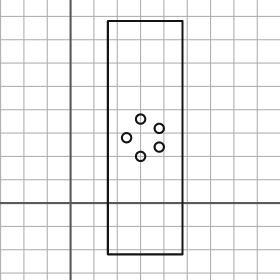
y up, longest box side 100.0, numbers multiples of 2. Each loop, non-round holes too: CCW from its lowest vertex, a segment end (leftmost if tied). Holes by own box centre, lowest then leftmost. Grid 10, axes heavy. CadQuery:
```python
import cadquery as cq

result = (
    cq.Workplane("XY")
    .moveTo(16.0, -22.0)
    .lineTo(48.0, -22.0)
    .lineTo(48.0, 78.0)
    .lineTo(16.0, 78.0)
    .close()
    .moveTo(30.0, 20.0)
    .circle(2.0)
    .moveTo(38.0, 24.0)
    .circle(2.0)
    .moveTo(24.0, 28.0)
    .circle(2.0)
    .moveTo(38.0, 32.0)
    .circle(2.0)
    .moveTo(30.0, 36.0)
    .circle(2.0)
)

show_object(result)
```